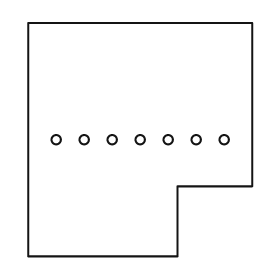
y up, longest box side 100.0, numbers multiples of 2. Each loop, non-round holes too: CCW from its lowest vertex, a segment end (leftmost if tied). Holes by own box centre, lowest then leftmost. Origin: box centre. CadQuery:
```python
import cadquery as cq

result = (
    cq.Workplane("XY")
    .moveTo(-48.0, -50.0)
    .lineTo(16.0, -50.0)
    .lineTo(16.0, -20.0)
    .lineTo(48.0, -20.0)
    .lineTo(48.0, 50.0)
    .lineTo(-48.0, 50.0)
    .close()
    .moveTo(-36.0, 0.0)
    .circle(2.0)
    .moveTo(-24.0, 0.0)
    .circle(2.0)
    .moveTo(-12.0, 0.0)
    .circle(2.0)
    .moveTo(0.0, 0.0)
    .circle(2.0)
    .moveTo(12.0, 0.0)
    .circle(2.0)
    .moveTo(24.0, 0.0)
    .circle(2.0)
    .moveTo(36.0, 0.0)
    .circle(2.0)
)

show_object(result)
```